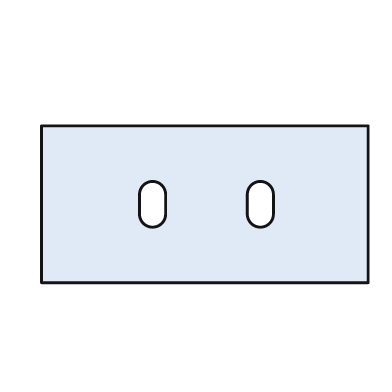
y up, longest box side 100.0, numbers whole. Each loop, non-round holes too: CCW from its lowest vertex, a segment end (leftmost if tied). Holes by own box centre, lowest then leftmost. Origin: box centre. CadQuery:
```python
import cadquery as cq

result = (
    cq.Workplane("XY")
    .moveTo(-50.0, -24.0)
    .lineTo(50.0, -24.0)
    .lineTo(50.0, 24.0)
    .lineTo(-50.0, 24.0)
    .close()
    .moveTo(-20.0, -3.0)
    .threePointArc((-16.0, -7.0), (-12.0, -3.0))
    .lineTo(-12.0, 3.0)
    .threePointArc((-16.0, 7.0), (-20.0, 3.0))
    .close()
    .moveTo(13.0, -3.0)
    .threePointArc((17.0, -7.0), (21.0, -3.0))
    .lineTo(21.0, 3.0)
    .threePointArc((17.0, 7.0), (13.0, 3.0))
    .close()
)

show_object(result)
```